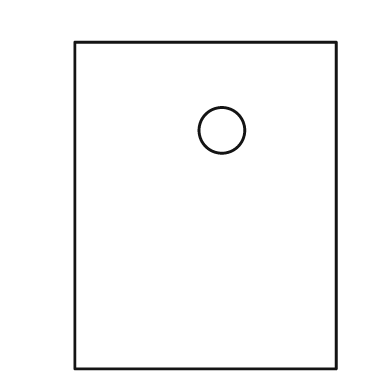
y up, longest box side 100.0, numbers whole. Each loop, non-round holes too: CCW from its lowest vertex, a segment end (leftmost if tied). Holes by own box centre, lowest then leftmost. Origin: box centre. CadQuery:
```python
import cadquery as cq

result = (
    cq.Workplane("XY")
    .moveTo(-40.0, -50.0)
    .lineTo(40.0, -50.0)
    .lineTo(40.0, 50.0)
    .lineTo(-40.0, 50.0)
    .close()
    .moveTo(5.0, 23.0)
    .circle(7.0)
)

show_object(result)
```